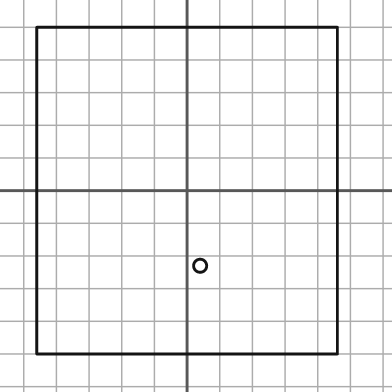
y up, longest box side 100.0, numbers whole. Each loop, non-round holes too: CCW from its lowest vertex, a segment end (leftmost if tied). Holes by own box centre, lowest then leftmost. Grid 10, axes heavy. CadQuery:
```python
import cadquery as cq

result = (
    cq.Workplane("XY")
    .moveTo(-46.0, -50.0)
    .lineTo(46.0, -50.0)
    .lineTo(46.0, 50.0)
    .lineTo(-46.0, 50.0)
    .close()
    .moveTo(4.0, -23.0)
    .circle(2.0)
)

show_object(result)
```